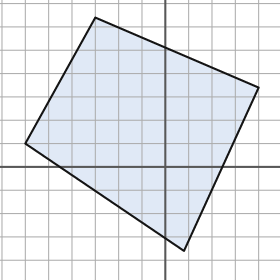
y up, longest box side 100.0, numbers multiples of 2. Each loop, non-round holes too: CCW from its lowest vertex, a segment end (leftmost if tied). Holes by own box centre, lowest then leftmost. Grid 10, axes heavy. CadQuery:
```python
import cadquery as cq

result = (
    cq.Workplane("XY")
    .moveTo(8.0, -36.0)
    .lineTo(40.0, 34.0)
    .lineTo(-30.0, 64.0)
    .lineTo(-60.0, 10.0)
    .close()
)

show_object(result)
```